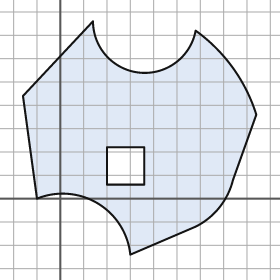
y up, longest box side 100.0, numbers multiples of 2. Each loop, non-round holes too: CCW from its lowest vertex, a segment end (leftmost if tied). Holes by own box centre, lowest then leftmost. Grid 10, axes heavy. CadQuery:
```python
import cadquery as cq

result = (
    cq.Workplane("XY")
    .moveTo(30.0, -24.0)
    .lineTo(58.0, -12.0)
    .threePointArc((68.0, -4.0), (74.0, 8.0))
    .lineTo(84.0, 36.0)
    .threePointArc((74.0, 56.0), (58.0, 72.0))
    .threePointArc((34.0, 54.0), (14.0, 76.0))
    .lineTo(-16.0, 44.0)
    .lineTo(-10.0, 0.0)
    .threePointArc((16.0, -2.0), (30.0, -24.0))
    .close()
    .moveTo(20.0, 6.0)
    .lineTo(36.0, 6.0)
    .lineTo(36.0, 22.0)
    .lineTo(20.0, 22.0)
    .close()
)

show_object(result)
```